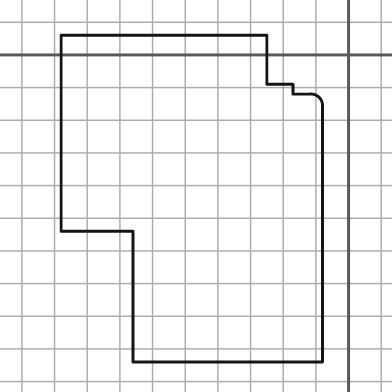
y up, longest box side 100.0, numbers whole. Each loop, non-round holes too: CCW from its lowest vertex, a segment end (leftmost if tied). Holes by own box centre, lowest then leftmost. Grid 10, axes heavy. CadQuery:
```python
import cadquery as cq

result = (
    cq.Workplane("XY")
    .moveTo(-66.0, -94.0)
    .lineTo(-8.0, -94.0)
    .lineTo(-8.0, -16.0)
    .threePointArc((-9.0, -13.0), (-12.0, -12.0))
    .lineTo(-17.0, -12.0)
    .lineTo(-17.0, -9.0)
    .lineTo(-25.0, -9.0)
    .lineTo(-25.0, 6.0)
    .lineTo(-88.0, 6.0)
    .lineTo(-88.0, -54.0)
    .lineTo(-66.0, -54.0)
    .close()
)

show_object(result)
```